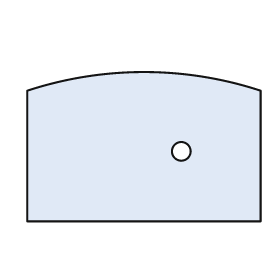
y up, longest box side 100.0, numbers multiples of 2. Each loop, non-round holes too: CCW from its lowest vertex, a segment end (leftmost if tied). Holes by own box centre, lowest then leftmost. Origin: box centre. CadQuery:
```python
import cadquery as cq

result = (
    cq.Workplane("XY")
    .moveTo(-50.0, -32.0)
    .lineTo(50.0, -32.0)
    .lineTo(50.0, 24.0)
    .threePointArc((0.0, 32.0), (-50.0, 24.0))
    .close()
    .moveTo(16.0, -2.0)
    .circle(4.0)
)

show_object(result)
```